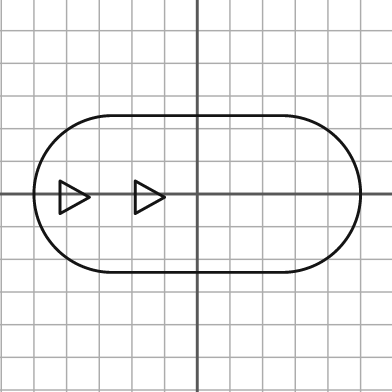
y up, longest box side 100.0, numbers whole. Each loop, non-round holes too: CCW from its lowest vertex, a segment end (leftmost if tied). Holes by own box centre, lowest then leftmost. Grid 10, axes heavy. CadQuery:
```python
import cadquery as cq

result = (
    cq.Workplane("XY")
    .moveTo(-26.0, -24.0)
    .lineTo(26.0, -24.0)
    .threePointArc((50.0, 0.0), (26.0, 24.0))
    .lineTo(-26.0, 24.0)
    .threePointArc((-50.0, 0.0), (-26.0, -24.0))
    .close()
    .moveTo(-42.0, -6.0)
    .lineTo(-33.0, -1.0)
    .lineTo(-42.0, 4.0)
    .close()
    .moveTo(-19.0, -6.0)
    .lineTo(-10.0, -1.0)
    .lineTo(-19.0, 4.0)
    .close()
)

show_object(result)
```